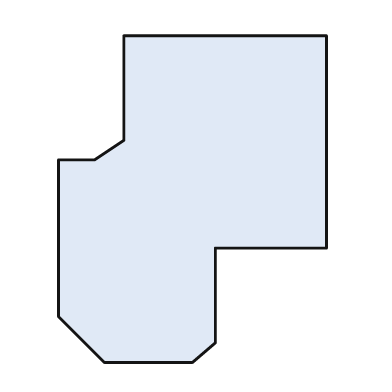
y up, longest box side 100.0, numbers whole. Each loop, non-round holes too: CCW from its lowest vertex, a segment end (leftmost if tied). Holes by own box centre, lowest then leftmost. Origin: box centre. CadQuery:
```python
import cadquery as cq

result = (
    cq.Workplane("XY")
    .moveTo(-27.0, -50.0)
    .lineTo(0.0, -50.0)
    .lineTo(7.0, -44.0)
    .lineTo(7.0, -15.0)
    .lineTo(41.0, -15.0)
    .lineTo(41.0, 50.0)
    .lineTo(-21.0, 50.0)
    .lineTo(-21.0, 18.0)
    .lineTo(-30.0, 12.0)
    .lineTo(-41.0, 12.0)
    .lineTo(-41.0, -36.0)
    .close()
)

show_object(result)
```